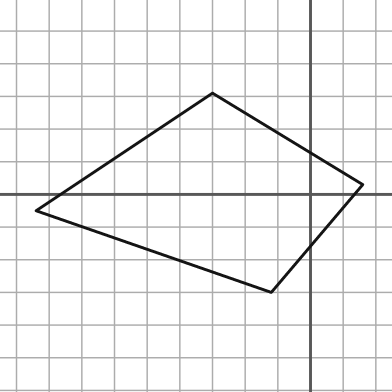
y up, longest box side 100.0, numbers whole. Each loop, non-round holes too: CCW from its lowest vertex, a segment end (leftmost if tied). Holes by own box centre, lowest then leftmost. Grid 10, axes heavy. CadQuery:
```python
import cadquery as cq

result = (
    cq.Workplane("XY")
    .moveTo(-12.0, -30.0)
    .lineTo(16.0, 3.0)
    .lineTo(-30.0, 31.0)
    .lineTo(-84.0, -5.0)
    .close()
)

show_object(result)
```